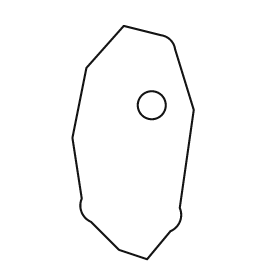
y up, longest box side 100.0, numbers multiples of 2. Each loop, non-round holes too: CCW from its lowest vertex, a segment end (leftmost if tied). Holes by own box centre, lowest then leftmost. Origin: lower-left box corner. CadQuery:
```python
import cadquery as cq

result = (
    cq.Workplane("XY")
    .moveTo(32.0, 0.0)
    .lineTo(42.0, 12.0)
    .threePointArc((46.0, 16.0), (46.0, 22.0))
    .lineTo(52.0, 64.0)
    .lineTo(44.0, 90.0)
    .threePointArc((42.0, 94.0), (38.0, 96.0))
    .lineTo(22.0, 100.0)
    .lineTo(6.0, 82.0)
    .lineTo(0.0, 52.0)
    .lineTo(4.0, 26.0)
    .threePointArc((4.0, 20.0), (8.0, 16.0))
    .lineTo(20.0, 4.0)
    .close()
    .moveTo(34.0, 66.0)
    .circle(6.0)
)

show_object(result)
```